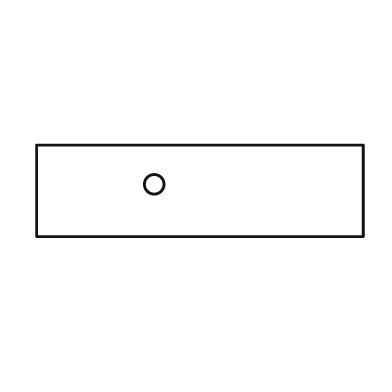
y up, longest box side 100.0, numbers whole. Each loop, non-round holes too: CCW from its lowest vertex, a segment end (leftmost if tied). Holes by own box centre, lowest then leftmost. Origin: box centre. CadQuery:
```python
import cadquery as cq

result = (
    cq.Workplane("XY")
    .moveTo(-50.0, -14.0)
    .lineTo(50.0, -14.0)
    .lineTo(50.0, 14.0)
    .lineTo(-50.0, 14.0)
    .close()
    .moveTo(-14.0, 2.0)
    .circle(3.0)
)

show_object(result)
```